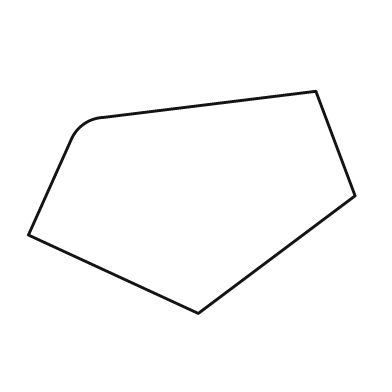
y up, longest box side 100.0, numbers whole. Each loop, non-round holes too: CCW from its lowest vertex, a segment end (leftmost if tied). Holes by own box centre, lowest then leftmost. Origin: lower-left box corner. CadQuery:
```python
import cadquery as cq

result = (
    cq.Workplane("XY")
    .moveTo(52.0, 0.0)
    .lineTo(100.0, 36.0)
    .lineTo(88.0, 68.0)
    .lineTo(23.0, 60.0)
    .threePointArc((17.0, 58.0), (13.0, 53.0))
    .lineTo(0.0, 24.0)
    .close()
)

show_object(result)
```